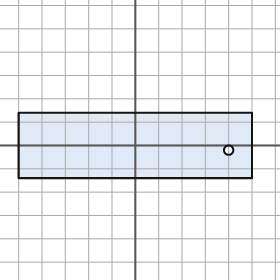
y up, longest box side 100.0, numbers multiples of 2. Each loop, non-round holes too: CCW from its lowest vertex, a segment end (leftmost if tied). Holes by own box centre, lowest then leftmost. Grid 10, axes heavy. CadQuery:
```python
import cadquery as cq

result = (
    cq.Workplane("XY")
    .moveTo(-50.0, -14.0)
    .lineTo(50.0, -14.0)
    .lineTo(50.0, 14.0)
    .lineTo(-50.0, 14.0)
    .close()
    .moveTo(40.0, -2.0)
    .circle(2.0)
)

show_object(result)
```